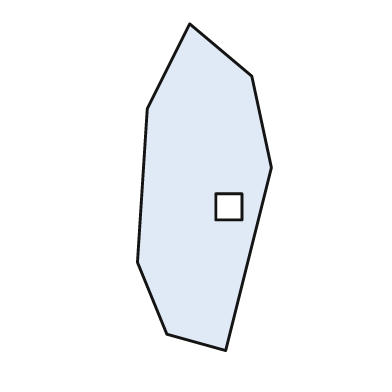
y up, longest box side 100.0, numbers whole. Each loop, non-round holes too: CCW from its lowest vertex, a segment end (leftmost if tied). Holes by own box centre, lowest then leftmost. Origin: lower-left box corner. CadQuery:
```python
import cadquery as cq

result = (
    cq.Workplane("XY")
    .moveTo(27.0, 0.0)
    .lineTo(41.0, 56.0)
    .lineTo(35.0, 84.0)
    .lineTo(16.0, 100.0)
    .lineTo(3.0, 74.0)
    .lineTo(0.0, 27.0)
    .lineTo(9.0, 5.0)
    .close()
    .moveTo(24.0, 40.0)
    .lineTo(32.0, 40.0)
    .lineTo(32.0, 48.0)
    .lineTo(24.0, 48.0)
    .close()
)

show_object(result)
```